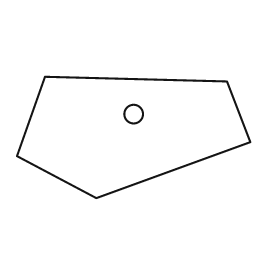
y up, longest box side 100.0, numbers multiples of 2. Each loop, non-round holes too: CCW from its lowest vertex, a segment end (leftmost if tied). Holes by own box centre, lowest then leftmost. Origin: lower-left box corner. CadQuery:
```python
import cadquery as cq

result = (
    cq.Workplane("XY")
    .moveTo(34.0, 0.0)
    .lineTo(100.0, 24.0)
    .lineTo(90.0, 50.0)
    .lineTo(12.0, 52.0)
    .lineTo(0.0, 18.0)
    .close()
    .moveTo(50.0, 36.0)
    .circle(4.0)
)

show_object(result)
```